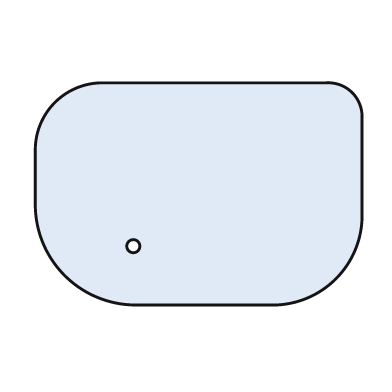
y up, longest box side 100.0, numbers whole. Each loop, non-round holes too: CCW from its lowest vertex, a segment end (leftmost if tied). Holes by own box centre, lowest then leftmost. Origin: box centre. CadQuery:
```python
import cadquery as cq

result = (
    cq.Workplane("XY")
    .moveTo(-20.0, -34.0)
    .lineTo(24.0, -34.0)
    .threePointArc((42.0, -26.0), (50.0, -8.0))
    .lineTo(50.0, 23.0)
    .threePointArc((47.0, 31.0), (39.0, 34.0))
    .lineTo(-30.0, 34.0)
    .threePointArc((-44.0, 28.0), (-50.0, 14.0))
    .lineTo(-50.0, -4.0)
    .threePointArc((-41.0, -25.0), (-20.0, -34.0))
    .close()
    .moveTo(-20.0, -16.0)
    .circle(2.0)
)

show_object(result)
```